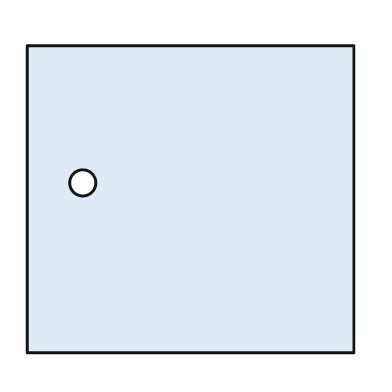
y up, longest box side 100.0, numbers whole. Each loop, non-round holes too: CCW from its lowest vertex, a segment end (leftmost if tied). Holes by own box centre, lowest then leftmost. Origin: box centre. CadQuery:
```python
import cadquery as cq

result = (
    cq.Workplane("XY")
    .moveTo(-50.0, -47.0)
    .lineTo(50.0, -47.0)
    .lineTo(50.0, 47.0)
    .lineTo(-50.0, 47.0)
    .close()
    .moveTo(-33.0, 5.0)
    .circle(4.0)
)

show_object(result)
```